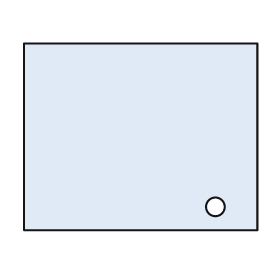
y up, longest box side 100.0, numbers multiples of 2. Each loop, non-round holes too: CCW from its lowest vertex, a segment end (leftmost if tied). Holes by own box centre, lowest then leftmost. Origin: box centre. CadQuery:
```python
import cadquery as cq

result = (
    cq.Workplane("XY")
    .moveTo(-50.0, -40.0)
    .lineTo(50.0, -40.0)
    .lineTo(50.0, 40.0)
    .lineTo(-50.0, 40.0)
    .close()
    .moveTo(32.0, -30.0)
    .circle(4.0)
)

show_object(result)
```